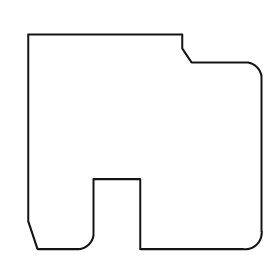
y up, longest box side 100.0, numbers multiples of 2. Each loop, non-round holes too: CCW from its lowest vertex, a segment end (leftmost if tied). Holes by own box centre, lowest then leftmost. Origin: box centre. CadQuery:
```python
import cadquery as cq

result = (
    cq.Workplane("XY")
    .moveTo(-46.0, -46.0)
    .lineTo(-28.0, -46.0)
    .threePointArc((-24.0, -44.0), (-22.0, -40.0))
    .lineTo(-22.0, -16.0)
    .lineTo(-2.0, -16.0)
    .lineTo(-2.0, -46.0)
    .lineTo(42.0, -46.0)
    .threePointArc((48.0, -44.0), (50.0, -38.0))
    .lineTo(50.0, 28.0)
    .threePointArc((48.0, 32.0), (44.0, 34.0))
    .lineTo(20.0, 34.0)
    .lineTo(16.0, 40.0)
    .lineTo(16.0, 46.0)
    .lineTo(-50.0, 46.0)
    .lineTo(-50.0, -34.0)
    .close()
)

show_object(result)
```